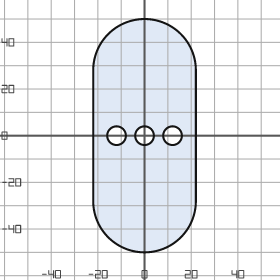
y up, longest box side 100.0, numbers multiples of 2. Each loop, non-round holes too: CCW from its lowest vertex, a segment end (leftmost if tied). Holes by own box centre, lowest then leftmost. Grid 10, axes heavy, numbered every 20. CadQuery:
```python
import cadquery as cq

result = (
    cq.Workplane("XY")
    .moveTo(-22.0, -28.0)
    .threePointArc((0.0, -50.0), (22.0, -28.0))
    .lineTo(22.0, 28.0)
    .threePointArc((0.0, 50.0), (-22.0, 28.0))
    .close()
    .moveTo(-12.0, 0.0)
    .circle(4.0)
    .moveTo(0.0, 0.0)
    .circle(4.0)
    .moveTo(12.0, 0.0)
    .circle(4.0)
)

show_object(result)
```